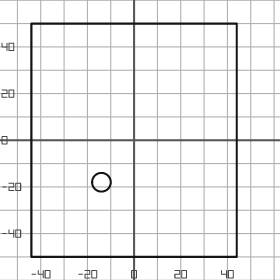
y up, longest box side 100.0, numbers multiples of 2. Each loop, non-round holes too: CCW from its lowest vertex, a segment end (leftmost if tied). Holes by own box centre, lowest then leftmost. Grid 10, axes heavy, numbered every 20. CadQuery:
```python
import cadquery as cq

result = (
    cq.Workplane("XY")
    .moveTo(-44.0, -50.0)
    .lineTo(44.0, -50.0)
    .lineTo(44.0, 50.0)
    .lineTo(-44.0, 50.0)
    .close()
    .moveTo(-14.0, -18.0)
    .circle(4.0)
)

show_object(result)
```